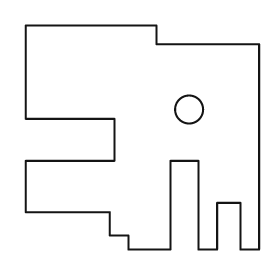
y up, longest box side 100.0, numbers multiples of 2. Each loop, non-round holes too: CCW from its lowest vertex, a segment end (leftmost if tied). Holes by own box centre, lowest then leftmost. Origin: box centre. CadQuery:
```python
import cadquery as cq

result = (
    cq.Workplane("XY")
    .moveTo(-6.0, -48.0)
    .lineTo(12.0, -48.0)
    .lineTo(12.0, -10.0)
    .lineTo(24.0, -10.0)
    .lineTo(24.0, -48.0)
    .lineTo(32.0, -48.0)
    .lineTo(32.0, -28.0)
    .lineTo(42.0, -28.0)
    .lineTo(42.0, -48.0)
    .lineTo(50.0, -48.0)
    .lineTo(50.0, 40.0)
    .lineTo(6.0, 40.0)
    .lineTo(6.0, 48.0)
    .lineTo(-50.0, 48.0)
    .lineTo(-50.0, 8.0)
    .lineTo(-12.0, 8.0)
    .lineTo(-12.0, -10.0)
    .lineTo(-50.0, -10.0)
    .lineTo(-50.0, -32.0)
    .lineTo(-14.0, -32.0)
    .lineTo(-14.0, -42.0)
    .lineTo(-6.0, -42.0)
    .close()
    .moveTo(20.0, 12.0)
    .circle(6.0)
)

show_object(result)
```